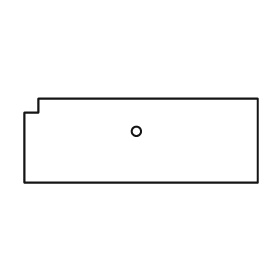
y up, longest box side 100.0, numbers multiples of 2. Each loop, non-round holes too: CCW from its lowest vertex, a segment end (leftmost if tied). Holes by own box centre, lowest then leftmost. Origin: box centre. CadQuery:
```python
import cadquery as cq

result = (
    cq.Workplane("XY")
    .moveTo(-50.0, -18.0)
    .lineTo(50.0, -18.0)
    .lineTo(50.0, 18.0)
    .lineTo(-44.0, 18.0)
    .lineTo(-44.0, 12.0)
    .lineTo(-50.0, 12.0)
    .close()
    .moveTo(-2.0, 4.0)
    .circle(2.0)
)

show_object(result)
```